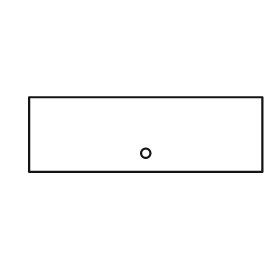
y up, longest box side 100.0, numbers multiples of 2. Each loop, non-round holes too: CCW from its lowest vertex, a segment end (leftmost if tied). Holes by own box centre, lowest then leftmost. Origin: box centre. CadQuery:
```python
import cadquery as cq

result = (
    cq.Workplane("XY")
    .moveTo(-50.0, -16.0)
    .lineTo(50.0, -16.0)
    .lineTo(50.0, 16.0)
    .lineTo(-50.0, 16.0)
    .close()
    .moveTo(0.0, -8.0)
    .circle(2.0)
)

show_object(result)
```